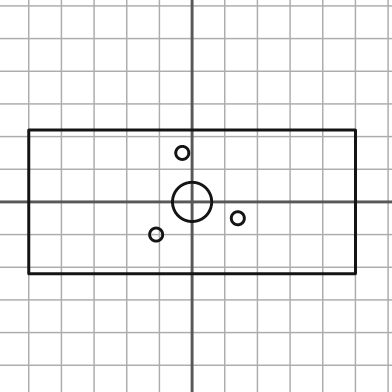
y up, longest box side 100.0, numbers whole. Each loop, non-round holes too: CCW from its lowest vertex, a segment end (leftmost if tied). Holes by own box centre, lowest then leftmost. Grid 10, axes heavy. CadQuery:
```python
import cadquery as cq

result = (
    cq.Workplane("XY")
    .moveTo(-50.0, -22.0)
    .lineTo(50.0, -22.0)
    .lineTo(50.0, 22.0)
    .lineTo(-50.0, 22.0)
    .close()
    .moveTo(-11.0, -10.0)
    .circle(2.0)
    .moveTo(14.0, -5.0)
    .circle(2.0)
    .moveTo(0.0, 0.0)
    .circle(6.0)
    .moveTo(-3.0, 15.0)
    .circle(2.0)
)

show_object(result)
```